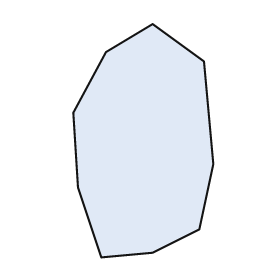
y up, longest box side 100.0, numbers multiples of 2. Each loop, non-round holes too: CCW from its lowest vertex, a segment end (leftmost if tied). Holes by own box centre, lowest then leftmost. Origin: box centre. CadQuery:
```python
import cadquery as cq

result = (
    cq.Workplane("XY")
    .moveTo(-18.0, -50.0)
    .lineTo(4.0, -48.0)
    .lineTo(24.0, -38.0)
    .lineTo(30.0, -10.0)
    .lineTo(26.0, 34.0)
    .lineTo(4.0, 50.0)
    .lineTo(-16.0, 38.0)
    .lineTo(-30.0, 12.0)
    .lineTo(-28.0, -20.0)
    .close()
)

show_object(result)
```